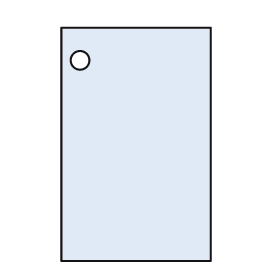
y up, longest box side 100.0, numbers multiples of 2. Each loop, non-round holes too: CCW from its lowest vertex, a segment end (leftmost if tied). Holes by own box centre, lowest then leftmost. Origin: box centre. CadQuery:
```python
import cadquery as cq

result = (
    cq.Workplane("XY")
    .moveTo(-32.0, -50.0)
    .lineTo(32.0, -50.0)
    .lineTo(32.0, 50.0)
    .lineTo(-32.0, 50.0)
    .close()
    .moveTo(-24.0, 36.0)
    .circle(4.0)
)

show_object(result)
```